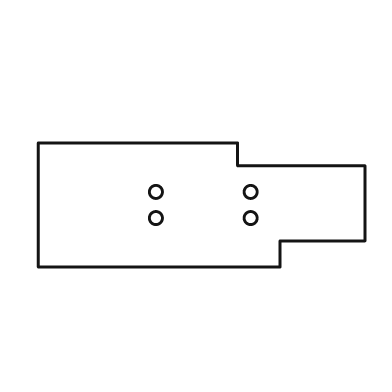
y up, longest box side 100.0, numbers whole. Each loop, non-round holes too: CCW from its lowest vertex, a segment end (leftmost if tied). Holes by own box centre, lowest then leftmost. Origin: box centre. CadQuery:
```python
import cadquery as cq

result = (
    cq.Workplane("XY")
    .moveTo(-50.0, -19.0)
    .lineTo(24.0, -19.0)
    .lineTo(24.0, -11.0)
    .lineTo(50.0, -11.0)
    .lineTo(50.0, 12.0)
    .lineTo(11.0, 12.0)
    .lineTo(11.0, 19.0)
    .lineTo(-50.0, 19.0)
    .close()
    .moveTo(-14.0, -4.0)
    .circle(2.0)
    .moveTo(15.0, -4.0)
    .circle(2.0)
    .moveTo(-14.0, 4.0)
    .circle(2.0)
    .moveTo(15.0, 4.0)
    .circle(2.0)
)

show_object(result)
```